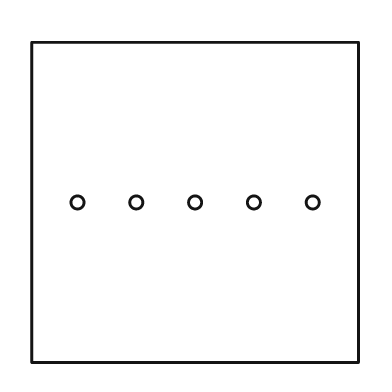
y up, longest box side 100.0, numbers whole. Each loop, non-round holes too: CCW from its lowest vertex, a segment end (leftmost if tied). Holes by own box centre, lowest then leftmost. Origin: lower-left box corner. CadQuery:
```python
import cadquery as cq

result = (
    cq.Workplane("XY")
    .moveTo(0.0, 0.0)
    .lineTo(100.0, 0.0)
    .lineTo(100.0, 98.0)
    .lineTo(0.0, 98.0)
    .close()
    .moveTo(14.0, 49.0)
    .circle(2.0)
    .moveTo(32.0, 49.0)
    .circle(2.0)
    .moveTo(50.0, 49.0)
    .circle(2.0)
    .moveTo(68.0, 49.0)
    .circle(2.0)
    .moveTo(86.0, 49.0)
    .circle(2.0)
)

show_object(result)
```